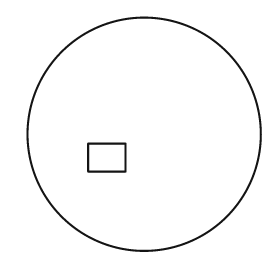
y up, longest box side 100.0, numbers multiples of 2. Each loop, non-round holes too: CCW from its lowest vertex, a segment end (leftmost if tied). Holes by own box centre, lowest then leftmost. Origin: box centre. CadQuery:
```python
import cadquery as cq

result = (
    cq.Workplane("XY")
    .moveTo(0.0, 0.0)
    .circle(50.0)
    .moveTo(-24.0, -16.0)
    .lineTo(-8.0, -16.0)
    .lineTo(-8.0, -4.0)
    .lineTo(-24.0, -4.0)
    .close()
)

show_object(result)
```